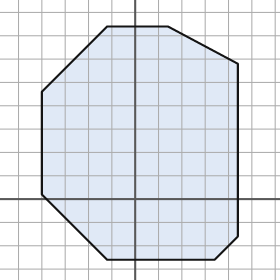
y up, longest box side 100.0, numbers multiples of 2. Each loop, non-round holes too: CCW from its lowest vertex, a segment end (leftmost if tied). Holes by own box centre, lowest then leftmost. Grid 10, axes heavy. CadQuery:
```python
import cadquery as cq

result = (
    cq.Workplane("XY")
    .moveTo(-12.0, -26.0)
    .lineTo(34.0, -26.0)
    .lineTo(44.0, -16.0)
    .lineTo(44.0, 58.0)
    .lineTo(14.0, 74.0)
    .lineTo(-12.0, 74.0)
    .lineTo(-40.0, 46.0)
    .lineTo(-40.0, 2.0)
    .close()
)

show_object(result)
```